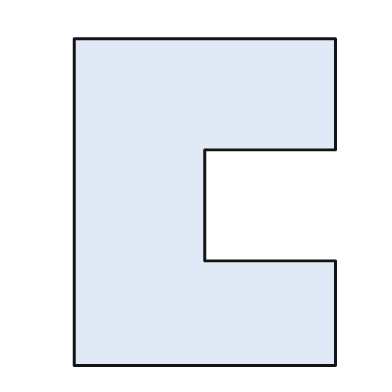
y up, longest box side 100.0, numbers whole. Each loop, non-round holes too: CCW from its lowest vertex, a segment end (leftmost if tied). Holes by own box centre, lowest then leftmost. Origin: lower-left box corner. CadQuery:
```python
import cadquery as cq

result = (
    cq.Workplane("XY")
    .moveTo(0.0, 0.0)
    .lineTo(80.0, 0.0)
    .lineTo(80.0, 32.0)
    .lineTo(40.0, 32.0)
    .lineTo(40.0, 66.0)
    .lineTo(80.0, 66.0)
    .lineTo(80.0, 100.0)
    .lineTo(0.0, 100.0)
    .close()
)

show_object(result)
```